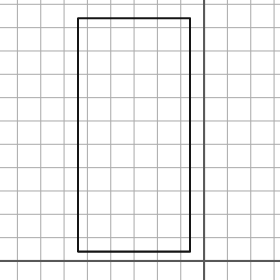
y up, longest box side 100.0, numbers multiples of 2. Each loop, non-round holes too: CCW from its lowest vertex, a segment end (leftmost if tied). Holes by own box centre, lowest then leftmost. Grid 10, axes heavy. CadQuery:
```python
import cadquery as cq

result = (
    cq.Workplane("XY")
    .moveTo(-54.0, 4.0)
    .lineTo(-6.0, 4.0)
    .lineTo(-6.0, 104.0)
    .lineTo(-54.0, 104.0)
    .close()
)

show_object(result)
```